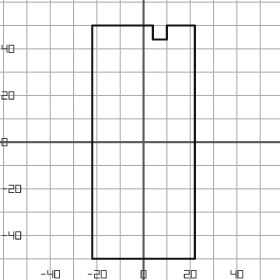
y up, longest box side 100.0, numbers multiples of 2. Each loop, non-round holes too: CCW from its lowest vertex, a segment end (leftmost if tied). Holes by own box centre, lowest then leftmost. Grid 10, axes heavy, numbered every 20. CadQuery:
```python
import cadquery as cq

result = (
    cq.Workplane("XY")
    .moveTo(-22.0, -50.0)
    .lineTo(22.0, -50.0)
    .lineTo(22.0, 50.0)
    .lineTo(10.0, 50.0)
    .lineTo(10.0, 44.0)
    .lineTo(4.0, 44.0)
    .lineTo(4.0, 50.0)
    .lineTo(-22.0, 50.0)
    .close()
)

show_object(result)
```